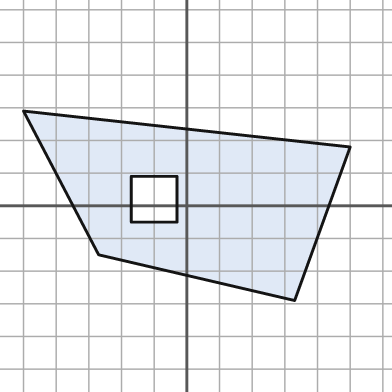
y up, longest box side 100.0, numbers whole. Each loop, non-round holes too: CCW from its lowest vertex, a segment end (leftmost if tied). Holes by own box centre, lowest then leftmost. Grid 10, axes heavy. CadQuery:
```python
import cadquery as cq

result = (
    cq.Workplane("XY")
    .moveTo(33.0, -29.0)
    .lineTo(50.0, 18.0)
    .lineTo(-50.0, 29.0)
    .lineTo(-27.0, -15.0)
    .close()
    .moveTo(-17.0, -5.0)
    .lineTo(-3.0, -5.0)
    .lineTo(-3.0, 9.0)
    .lineTo(-17.0, 9.0)
    .close()
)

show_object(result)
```